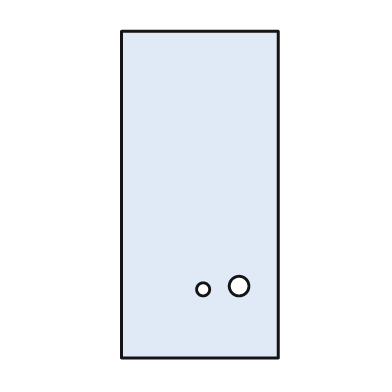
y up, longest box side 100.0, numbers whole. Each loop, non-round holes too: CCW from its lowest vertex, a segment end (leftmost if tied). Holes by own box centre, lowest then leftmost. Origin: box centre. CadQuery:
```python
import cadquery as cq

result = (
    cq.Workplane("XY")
    .moveTo(-24.0, -50.0)
    .lineTo(24.0, -50.0)
    .lineTo(24.0, 50.0)
    .lineTo(-24.0, 50.0)
    .close()
    .moveTo(1.0, -29.0)
    .circle(2.0)
    .moveTo(12.0, -28.0)
    .circle(3.0)
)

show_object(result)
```